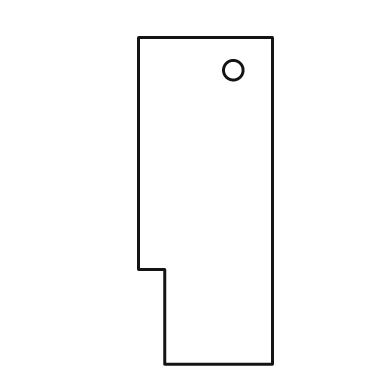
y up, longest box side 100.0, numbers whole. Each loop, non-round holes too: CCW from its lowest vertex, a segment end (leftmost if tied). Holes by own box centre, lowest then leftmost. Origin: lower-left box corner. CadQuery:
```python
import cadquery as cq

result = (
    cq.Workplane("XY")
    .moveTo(8.0, 0.0)
    .lineTo(41.0, 0.0)
    .lineTo(41.0, 100.0)
    .lineTo(0.0, 100.0)
    .lineTo(0.0, 29.0)
    .lineTo(8.0, 29.0)
    .close()
    .moveTo(29.0, 90.0)
    .circle(3.0)
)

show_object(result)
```